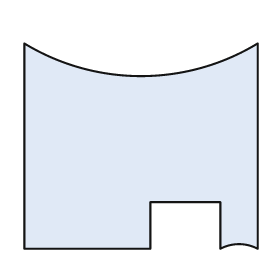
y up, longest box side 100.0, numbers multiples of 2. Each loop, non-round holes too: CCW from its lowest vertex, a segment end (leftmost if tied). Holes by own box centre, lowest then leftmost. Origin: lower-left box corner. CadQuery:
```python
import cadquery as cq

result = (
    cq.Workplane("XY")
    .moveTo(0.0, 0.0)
    .lineTo(54.0, 0.0)
    .lineTo(54.0, 20.0)
    .lineTo(84.0, 20.0)
    .lineTo(84.0, 0.0)
    .threePointArc((92.0, 2.0), (100.0, 0.0))
    .lineTo(100.0, 88.0)
    .threePointArc((50.0, 74.0), (0.0, 88.0))
    .close()
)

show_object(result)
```